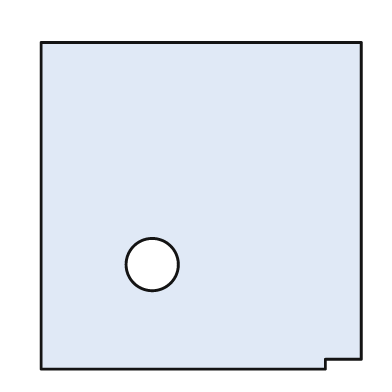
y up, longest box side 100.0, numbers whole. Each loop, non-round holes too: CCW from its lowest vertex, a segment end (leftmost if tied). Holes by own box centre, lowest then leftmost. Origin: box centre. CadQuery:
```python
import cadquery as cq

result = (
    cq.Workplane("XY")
    .moveTo(-49.0, -50.0)
    .lineTo(38.0, -50.0)
    .lineTo(38.0, -47.0)
    .lineTo(49.0, -47.0)
    .lineTo(49.0, 50.0)
    .lineTo(-49.0, 50.0)
    .close()
    .moveTo(-15.0, -18.0)
    .circle(8.0)
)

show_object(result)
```